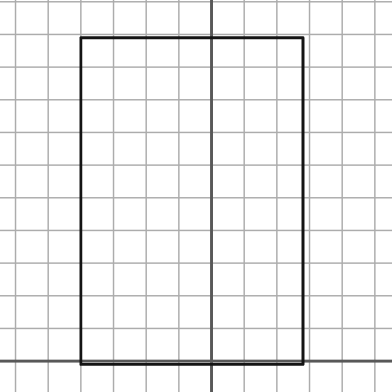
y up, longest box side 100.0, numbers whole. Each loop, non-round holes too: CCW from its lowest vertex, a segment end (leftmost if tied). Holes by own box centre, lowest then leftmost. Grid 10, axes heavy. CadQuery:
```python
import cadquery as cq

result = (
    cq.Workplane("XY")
    .moveTo(-40.0, -1.0)
    .lineTo(28.0, -1.0)
    .lineTo(28.0, 99.0)
    .lineTo(-40.0, 99.0)
    .close()
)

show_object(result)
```